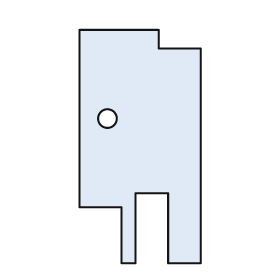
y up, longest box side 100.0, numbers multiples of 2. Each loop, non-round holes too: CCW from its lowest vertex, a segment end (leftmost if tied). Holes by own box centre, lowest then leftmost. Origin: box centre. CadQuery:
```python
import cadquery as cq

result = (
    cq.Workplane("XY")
    .moveTo(-8.0, -50.0)
    .lineTo(-2.0, -50.0)
    .lineTo(-2.0, -20.0)
    .lineTo(12.0, -20.0)
    .lineTo(12.0, -50.0)
    .lineTo(26.0, -50.0)
    .lineTo(26.0, 42.0)
    .lineTo(8.0, 42.0)
    .lineTo(8.0, 50.0)
    .lineTo(-26.0, 50.0)
    .lineTo(-26.0, -26.0)
    .lineTo(-8.0, -26.0)
    .close()
    .moveTo(-14.0, 12.0)
    .circle(4.0)
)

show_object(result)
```